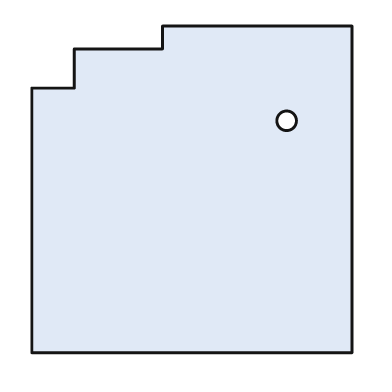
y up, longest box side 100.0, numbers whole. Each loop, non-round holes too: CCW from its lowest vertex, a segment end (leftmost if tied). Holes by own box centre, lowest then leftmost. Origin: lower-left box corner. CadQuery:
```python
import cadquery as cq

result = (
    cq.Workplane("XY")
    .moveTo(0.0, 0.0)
    .lineTo(98.0, 0.0)
    .lineTo(98.0, 100.0)
    .lineTo(40.0, 100.0)
    .lineTo(40.0, 93.0)
    .lineTo(13.0, 93.0)
    .lineTo(13.0, 81.0)
    .lineTo(0.0, 81.0)
    .close()
    .moveTo(78.0, 71.0)
    .circle(3.0)
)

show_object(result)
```